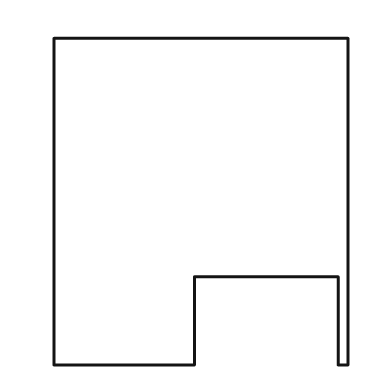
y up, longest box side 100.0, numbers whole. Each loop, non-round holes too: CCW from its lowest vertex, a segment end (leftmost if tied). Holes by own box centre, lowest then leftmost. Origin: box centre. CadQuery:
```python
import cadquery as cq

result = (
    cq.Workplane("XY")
    .moveTo(-45.0, -50.0)
    .lineTo(-2.0, -50.0)
    .lineTo(-2.0, -23.0)
    .lineTo(42.0, -23.0)
    .lineTo(42.0, -50.0)
    .lineTo(45.0, -50.0)
    .lineTo(45.0, 50.0)
    .lineTo(-45.0, 50.0)
    .close()
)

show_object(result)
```